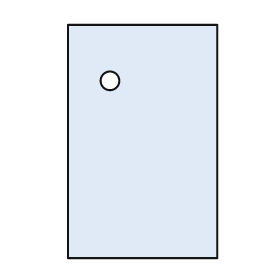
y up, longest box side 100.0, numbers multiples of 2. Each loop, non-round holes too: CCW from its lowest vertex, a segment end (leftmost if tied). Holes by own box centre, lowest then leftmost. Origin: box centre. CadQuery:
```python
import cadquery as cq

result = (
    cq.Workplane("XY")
    .moveTo(-32.0, -50.0)
    .lineTo(32.0, -50.0)
    .lineTo(32.0, 50.0)
    .lineTo(-32.0, 50.0)
    .close()
    .moveTo(-14.0, 26.0)
    .circle(4.0)
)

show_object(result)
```